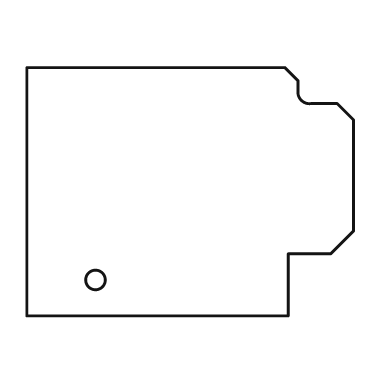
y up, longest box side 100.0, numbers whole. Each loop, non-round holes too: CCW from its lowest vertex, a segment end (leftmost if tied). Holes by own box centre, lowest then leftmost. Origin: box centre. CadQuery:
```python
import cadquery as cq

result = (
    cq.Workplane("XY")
    .moveTo(-50.0, -38.0)
    .lineTo(30.0, -38.0)
    .lineTo(30.0, -19.0)
    .lineTo(43.0, -19.0)
    .lineTo(50.0, -12.0)
    .lineTo(50.0, 22.0)
    .lineTo(45.0, 27.0)
    .lineTo(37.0, 27.0)
    .threePointArc((34.0, 28.0), (33.0, 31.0))
    .lineTo(33.0, 34.0)
    .lineTo(29.0, 38.0)
    .lineTo(-50.0, 38.0)
    .close()
    .moveTo(-29.0, -27.0)
    .circle(3.0)
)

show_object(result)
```